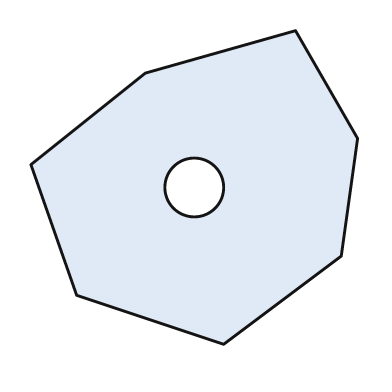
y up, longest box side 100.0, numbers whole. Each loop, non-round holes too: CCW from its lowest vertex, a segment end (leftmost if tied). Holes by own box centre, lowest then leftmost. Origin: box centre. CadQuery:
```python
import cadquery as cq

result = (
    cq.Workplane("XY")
    .moveTo(9.0, -48.0)
    .lineTo(45.0, -21.0)
    .lineTo(50.0, 15.0)
    .lineTo(31.0, 48.0)
    .lineTo(-15.0, 35.0)
    .lineTo(-50.0, 7.0)
    .lineTo(-36.0, -33.0)
    .close()
    .moveTo(0.0, 0.0)
    .circle(9.0)
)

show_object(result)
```